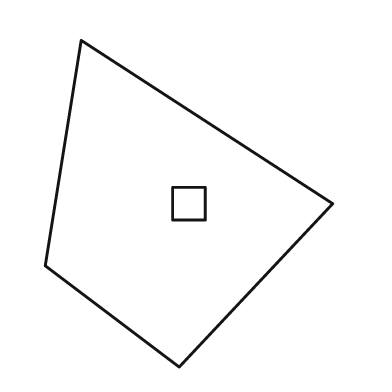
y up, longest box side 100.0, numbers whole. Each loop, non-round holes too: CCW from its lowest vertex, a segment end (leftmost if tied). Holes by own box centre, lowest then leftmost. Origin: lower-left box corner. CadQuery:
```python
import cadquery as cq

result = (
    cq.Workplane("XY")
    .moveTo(41.0, 0.0)
    .lineTo(88.0, 50.0)
    .lineTo(11.0, 100.0)
    .lineTo(0.0, 31.0)
    .close()
    .moveTo(39.0, 45.0)
    .lineTo(49.0, 45.0)
    .lineTo(49.0, 55.0)
    .lineTo(39.0, 55.0)
    .close()
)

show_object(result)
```